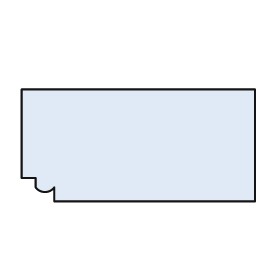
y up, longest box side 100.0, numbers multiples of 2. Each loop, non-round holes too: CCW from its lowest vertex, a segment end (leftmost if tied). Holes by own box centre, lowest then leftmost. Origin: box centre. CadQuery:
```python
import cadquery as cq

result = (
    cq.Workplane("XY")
    .moveTo(-36.0, -24.0)
    .lineTo(50.0, -24.0)
    .lineTo(50.0, 24.0)
    .lineTo(-50.0, 24.0)
    .lineTo(-50.0, -14.0)
    .lineTo(-44.0, -14.0)
    .lineTo(-44.0, -18.0)
    .threePointArc((-40.0, -20.0), (-36.0, -18.0))
    .close()
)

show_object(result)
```